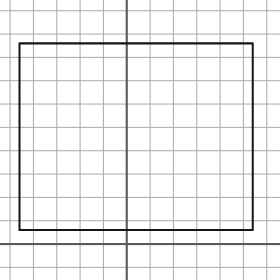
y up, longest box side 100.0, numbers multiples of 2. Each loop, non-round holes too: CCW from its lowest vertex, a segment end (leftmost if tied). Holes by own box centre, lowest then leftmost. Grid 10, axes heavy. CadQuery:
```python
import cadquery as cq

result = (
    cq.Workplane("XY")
    .moveTo(-46.0, 6.0)
    .lineTo(54.0, 6.0)
    .lineTo(54.0, 86.0)
    .lineTo(-46.0, 86.0)
    .close()
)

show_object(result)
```